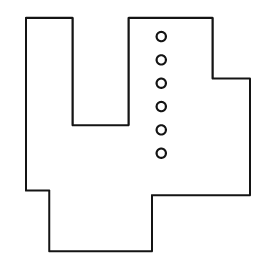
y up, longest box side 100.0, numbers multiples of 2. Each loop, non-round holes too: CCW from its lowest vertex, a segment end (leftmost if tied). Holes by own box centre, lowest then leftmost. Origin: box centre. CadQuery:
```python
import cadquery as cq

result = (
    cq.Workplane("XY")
    .moveTo(-38.0, -50.0)
    .lineTo(6.0, -50.0)
    .lineTo(6.0, -26.0)
    .lineTo(48.0, -26.0)
    .lineTo(48.0, 24.0)
    .lineTo(32.0, 24.0)
    .lineTo(32.0, 50.0)
    .lineTo(-4.0, 50.0)
    .lineTo(-4.0, 4.0)
    .lineTo(-28.0, 4.0)
    .lineTo(-28.0, 50.0)
    .lineTo(-48.0, 50.0)
    .lineTo(-48.0, -24.0)
    .lineTo(-38.0, -24.0)
    .close()
    .moveTo(10.0, -8.0)
    .circle(2.0)
    .moveTo(10.0, 2.0)
    .circle(2.0)
    .moveTo(10.0, 12.0)
    .circle(2.0)
    .moveTo(10.0, 22.0)
    .circle(2.0)
    .moveTo(10.0, 32.0)
    .circle(2.0)
    .moveTo(10.0, 42.0)
    .circle(2.0)
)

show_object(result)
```